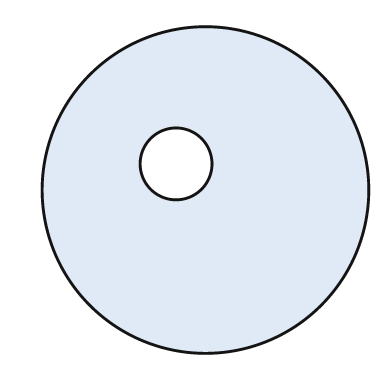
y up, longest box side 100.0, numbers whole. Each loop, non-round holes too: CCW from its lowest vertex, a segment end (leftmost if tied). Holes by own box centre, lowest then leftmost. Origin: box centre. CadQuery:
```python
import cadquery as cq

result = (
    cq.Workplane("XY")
    .moveTo(0.0, 0.0)
    .circle(50.0)
    .moveTo(-9.0, 8.0)
    .circle(11.0)
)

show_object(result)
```